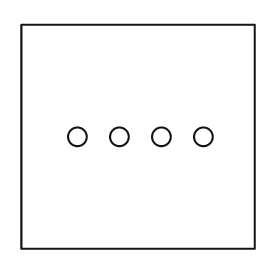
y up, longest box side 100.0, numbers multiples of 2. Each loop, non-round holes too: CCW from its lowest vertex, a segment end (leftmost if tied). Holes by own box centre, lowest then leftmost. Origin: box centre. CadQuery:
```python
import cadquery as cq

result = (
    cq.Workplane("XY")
    .moveTo(-50.0, -48.0)
    .lineTo(50.0, -48.0)
    .lineTo(50.0, 48.0)
    .lineTo(-50.0, 48.0)
    .close()
    .moveTo(-26.0, 0.0)
    .circle(4.0)
    .moveTo(-8.0, 0.0)
    .circle(4.0)
    .moveTo(10.0, 0.0)
    .circle(4.0)
    .moveTo(28.0, 0.0)
    .circle(4.0)
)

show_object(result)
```